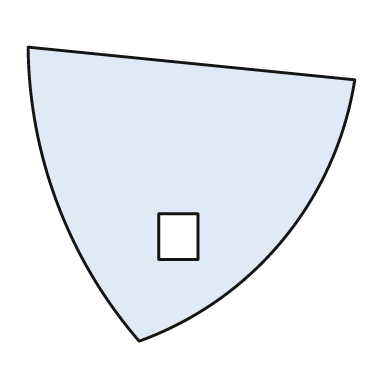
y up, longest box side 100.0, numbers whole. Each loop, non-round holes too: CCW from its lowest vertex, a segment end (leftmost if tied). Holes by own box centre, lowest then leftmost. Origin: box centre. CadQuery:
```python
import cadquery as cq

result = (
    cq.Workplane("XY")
    .moveTo(-16.0, -45.0)
    .threePointArc((28.0, -14.0), (50.0, 35.0))
    .lineTo(-50.0, 45.0)
    .threePointArc((-41.0, -3.0), (-16.0, -45.0))
    .close()
    .moveTo(-10.0, -20.0)
    .lineTo(2.0, -20.0)
    .lineTo(2.0, -6.0)
    .lineTo(-10.0, -6.0)
    .close()
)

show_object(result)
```